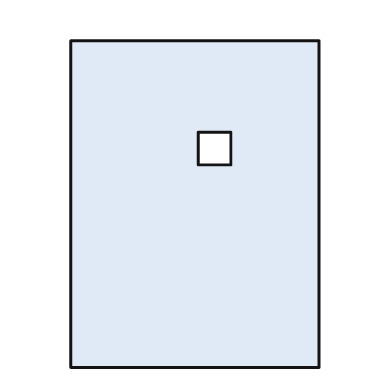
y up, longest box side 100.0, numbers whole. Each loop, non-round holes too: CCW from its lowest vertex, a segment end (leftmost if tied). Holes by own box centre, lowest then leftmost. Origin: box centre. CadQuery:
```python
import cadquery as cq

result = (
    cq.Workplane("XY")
    .moveTo(-38.0, -50.0)
    .lineTo(38.0, -50.0)
    .lineTo(38.0, 50.0)
    .lineTo(-38.0, 50.0)
    .close()
    .moveTo(1.0, 12.0)
    .lineTo(11.0, 12.0)
    .lineTo(11.0, 22.0)
    .lineTo(1.0, 22.0)
    .close()
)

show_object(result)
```